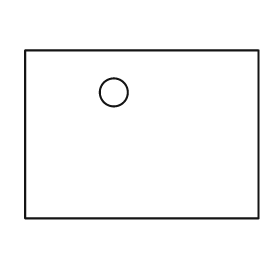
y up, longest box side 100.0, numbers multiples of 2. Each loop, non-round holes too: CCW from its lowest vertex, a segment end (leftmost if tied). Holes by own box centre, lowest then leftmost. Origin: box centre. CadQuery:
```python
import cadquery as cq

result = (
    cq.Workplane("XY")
    .moveTo(-50.0, -36.0)
    .lineTo(50.0, -36.0)
    .lineTo(50.0, 36.0)
    .lineTo(-50.0, 36.0)
    .close()
    .moveTo(-12.0, 18.0)
    .circle(6.0)
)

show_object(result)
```